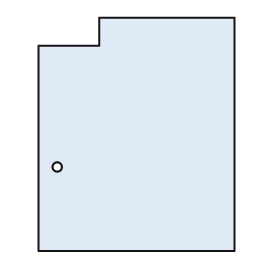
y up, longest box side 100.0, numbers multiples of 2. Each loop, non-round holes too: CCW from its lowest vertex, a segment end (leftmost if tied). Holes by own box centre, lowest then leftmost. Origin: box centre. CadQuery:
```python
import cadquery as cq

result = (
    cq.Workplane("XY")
    .moveTo(-42.0, -50.0)
    .lineTo(42.0, -50.0)
    .lineTo(42.0, 50.0)
    .lineTo(-16.0, 50.0)
    .lineTo(-16.0, 38.0)
    .lineTo(-42.0, 38.0)
    .close()
    .moveTo(-34.0, -14.0)
    .circle(2.0)
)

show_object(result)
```